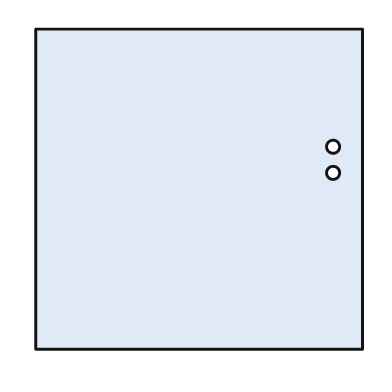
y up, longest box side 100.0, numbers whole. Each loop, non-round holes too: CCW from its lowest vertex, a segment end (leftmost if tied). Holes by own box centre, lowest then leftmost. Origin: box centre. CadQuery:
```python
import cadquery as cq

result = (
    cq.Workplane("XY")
    .moveTo(-50.0, -49.0)
    .lineTo(50.0, -49.0)
    .lineTo(50.0, 49.0)
    .lineTo(-50.0, 49.0)
    .close()
    .moveTo(41.0, 5.0)
    .circle(2.0)
    .moveTo(41.0, 13.0)
    .circle(2.0)
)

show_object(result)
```